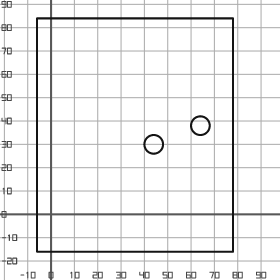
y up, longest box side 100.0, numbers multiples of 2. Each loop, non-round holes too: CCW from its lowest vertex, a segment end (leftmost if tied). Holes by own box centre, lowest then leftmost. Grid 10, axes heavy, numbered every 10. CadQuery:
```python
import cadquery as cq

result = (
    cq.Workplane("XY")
    .moveTo(-6.0, -16.0)
    .lineTo(78.0, -16.0)
    .lineTo(78.0, 84.0)
    .lineTo(-6.0, 84.0)
    .close()
    .moveTo(44.0, 30.0)
    .circle(4.0)
    .moveTo(64.0, 38.0)
    .circle(4.0)
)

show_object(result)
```